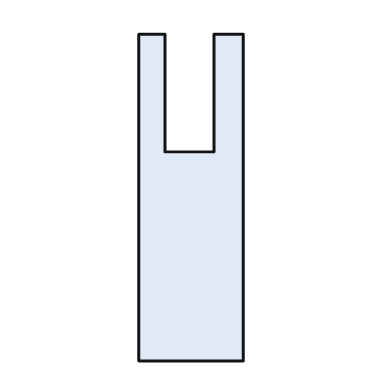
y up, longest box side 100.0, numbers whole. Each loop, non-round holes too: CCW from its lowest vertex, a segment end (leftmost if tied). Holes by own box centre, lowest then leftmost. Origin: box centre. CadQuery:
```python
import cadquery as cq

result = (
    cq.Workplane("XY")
    .moveTo(-16.0, -50.0)
    .lineTo(16.0, -50.0)
    .lineTo(16.0, 50.0)
    .lineTo(7.0, 50.0)
    .lineTo(7.0, 14.0)
    .lineTo(-8.0, 14.0)
    .lineTo(-8.0, 50.0)
    .lineTo(-16.0, 50.0)
    .close()
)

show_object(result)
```